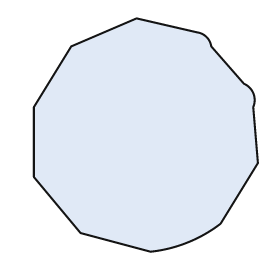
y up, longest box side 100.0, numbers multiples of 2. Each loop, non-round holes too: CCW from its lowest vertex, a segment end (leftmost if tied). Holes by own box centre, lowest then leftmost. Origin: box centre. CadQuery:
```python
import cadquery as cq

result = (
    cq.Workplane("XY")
    .moveTo(2.0, -50.0)
    .threePointArc((18.0, -46.0), (32.0, -38.0))
    .lineTo(48.0, -12.0)
    .lineTo(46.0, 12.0)
    .threePointArc((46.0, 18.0), (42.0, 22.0))
    .lineTo(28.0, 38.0)
    .threePointArc((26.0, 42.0), (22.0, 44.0))
    .lineTo(-4.0, 50.0)
    .lineTo(-32.0, 38.0)
    .lineTo(-48.0, 12.0)
    .lineTo(-48.0, -18.0)
    .lineTo(-28.0, -42.0)
    .close()
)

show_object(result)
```